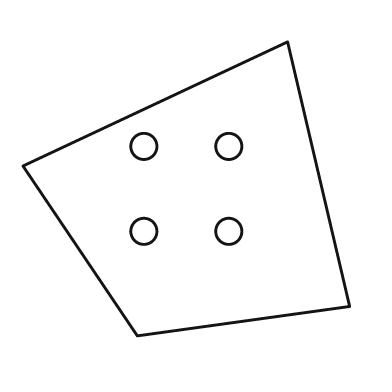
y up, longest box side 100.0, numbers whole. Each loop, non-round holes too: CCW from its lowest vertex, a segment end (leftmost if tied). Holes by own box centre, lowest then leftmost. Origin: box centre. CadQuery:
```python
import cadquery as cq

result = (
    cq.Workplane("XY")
    .moveTo(-15.0, -45.0)
    .lineTo(50.0, -36.0)
    .lineTo(31.0, 45.0)
    .lineTo(-50.0, 7.0)
    .close()
    .moveTo(-13.0, -13.0)
    .circle(4.0)
    .moveTo(13.0, -13.0)
    .circle(4.0)
    .moveTo(-13.0, 13.0)
    .circle(4.0)
    .moveTo(13.0, 13.0)
    .circle(4.0)
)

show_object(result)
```